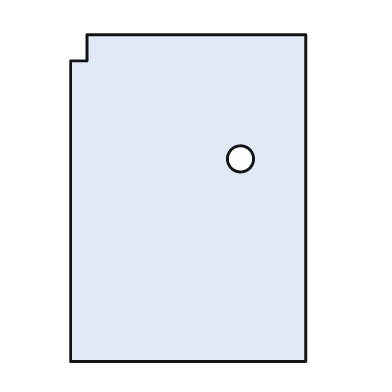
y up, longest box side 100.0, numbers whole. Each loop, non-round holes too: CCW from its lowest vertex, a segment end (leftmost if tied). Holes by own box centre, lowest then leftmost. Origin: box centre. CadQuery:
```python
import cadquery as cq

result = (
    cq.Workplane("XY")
    .moveTo(-36.0, -50.0)
    .lineTo(36.0, -50.0)
    .lineTo(36.0, 50.0)
    .lineTo(-31.0, 50.0)
    .lineTo(-31.0, 42.0)
    .lineTo(-36.0, 42.0)
    .close()
    .moveTo(16.0, 12.0)
    .circle(4.0)
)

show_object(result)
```